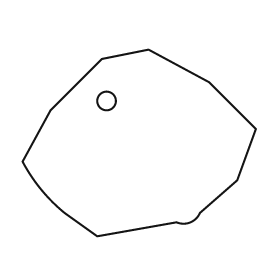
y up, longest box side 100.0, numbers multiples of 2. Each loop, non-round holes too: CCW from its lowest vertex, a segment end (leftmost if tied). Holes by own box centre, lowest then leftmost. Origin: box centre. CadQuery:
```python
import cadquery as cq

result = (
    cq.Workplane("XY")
    .moveTo(-18.0, -40.0)
    .lineTo(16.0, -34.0)
    .threePointArc((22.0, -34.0), (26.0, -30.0))
    .lineTo(42.0, -16.0)
    .lineTo(50.0, 6.0)
    .lineTo(30.0, 26.0)
    .lineTo(4.0, 40.0)
    .lineTo(-16.0, 36.0)
    .lineTo(-38.0, 14.0)
    .lineTo(-50.0, -8.0)
    .threePointArc((-42.0, -20.0), (-32.0, -30.0))
    .close()
    .moveTo(-14.0, 18.0)
    .circle(4.0)
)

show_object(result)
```